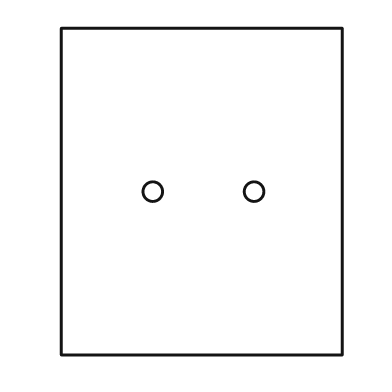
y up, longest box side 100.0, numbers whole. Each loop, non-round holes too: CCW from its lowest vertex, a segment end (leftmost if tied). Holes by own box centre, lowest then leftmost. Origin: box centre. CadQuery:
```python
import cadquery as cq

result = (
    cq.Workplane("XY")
    .moveTo(-43.0, -50.0)
    .lineTo(43.0, -50.0)
    .lineTo(43.0, 50.0)
    .lineTo(-43.0, 50.0)
    .close()
    .moveTo(-15.0, 0.0)
    .circle(3.0)
    .moveTo(16.0, 0.0)
    .circle(3.0)
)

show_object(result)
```